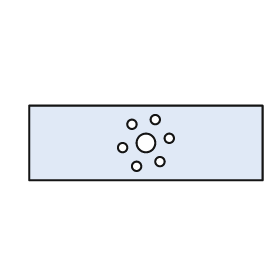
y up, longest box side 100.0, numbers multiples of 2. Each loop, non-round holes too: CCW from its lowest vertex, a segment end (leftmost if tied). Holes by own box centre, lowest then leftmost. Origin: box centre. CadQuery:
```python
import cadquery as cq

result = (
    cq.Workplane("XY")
    .moveTo(-50.0, -16.0)
    .lineTo(50.0, -16.0)
    .lineTo(50.0, 16.0)
    .lineTo(-50.0, 16.0)
    .close()
    .moveTo(-4.0, -10.0)
    .circle(2.0)
    .moveTo(6.0, -8.0)
    .circle(2.0)
    .moveTo(-10.0, -2.0)
    .circle(2.0)
    .moveTo(0.0, 0.0)
    .circle(4.0)
    .moveTo(10.0, 2.0)
    .circle(2.0)
    .moveTo(-6.0, 8.0)
    .circle(2.0)
    .moveTo(4.0, 10.0)
    .circle(2.0)
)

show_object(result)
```